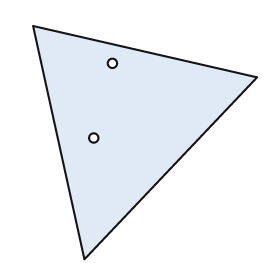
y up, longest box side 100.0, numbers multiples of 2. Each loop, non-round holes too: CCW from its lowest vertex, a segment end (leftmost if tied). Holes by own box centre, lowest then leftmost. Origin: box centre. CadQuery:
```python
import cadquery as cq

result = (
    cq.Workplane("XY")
    .moveTo(-26.0, -50.0)
    .lineTo(48.0, 28.0)
    .lineTo(-48.0, 50.0)
    .close()
    .moveTo(-22.0, 2.0)
    .circle(2.0)
    .moveTo(-14.0, 34.0)
    .circle(2.0)
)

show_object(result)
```